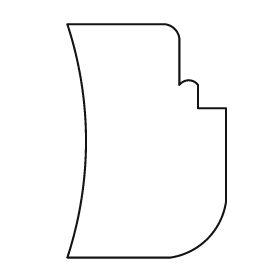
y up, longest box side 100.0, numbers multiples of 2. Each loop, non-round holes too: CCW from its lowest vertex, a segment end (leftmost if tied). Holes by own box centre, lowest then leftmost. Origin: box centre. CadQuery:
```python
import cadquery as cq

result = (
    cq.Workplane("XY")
    .moveTo(-34.0, -50.0)
    .lineTo(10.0, -50.0)
    .threePointArc((26.0, -42.0), (34.0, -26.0))
    .lineTo(34.0, 14.0)
    .lineTo(22.0, 14.0)
    .lineTo(22.0, 24.0)
    .threePointArc((18.0, 26.0), (14.0, 24.0))
    .lineTo(14.0, 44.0)
    .threePointArc((12.0, 48.0), (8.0, 50.0))
    .lineTo(-34.0, 50.0)
    .threePointArc((-26.0, 0.0), (-34.0, -50.0))
    .close()
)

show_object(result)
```